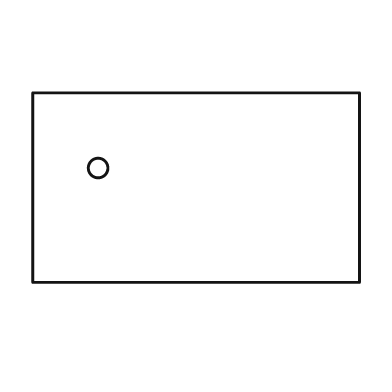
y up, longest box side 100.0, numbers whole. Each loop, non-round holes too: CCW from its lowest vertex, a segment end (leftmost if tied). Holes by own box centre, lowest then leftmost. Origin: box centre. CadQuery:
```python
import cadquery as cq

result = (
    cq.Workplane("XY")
    .moveTo(-50.0, -29.0)
    .lineTo(50.0, -29.0)
    .lineTo(50.0, 29.0)
    .lineTo(-50.0, 29.0)
    .close()
    .moveTo(-30.0, 6.0)
    .circle(3.0)
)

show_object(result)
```